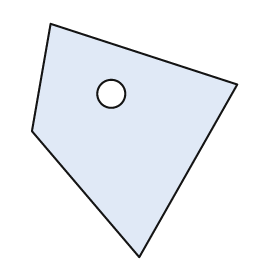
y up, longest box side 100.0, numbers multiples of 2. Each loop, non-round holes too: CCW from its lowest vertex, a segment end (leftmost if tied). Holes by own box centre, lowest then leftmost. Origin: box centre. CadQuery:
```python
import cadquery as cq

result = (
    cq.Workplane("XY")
    .moveTo(2.0, -50.0)
    .lineTo(44.0, 24.0)
    .lineTo(-36.0, 50.0)
    .lineTo(-44.0, 4.0)
    .close()
    .moveTo(-10.0, 20.0)
    .circle(6.0)
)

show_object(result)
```